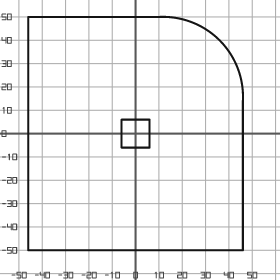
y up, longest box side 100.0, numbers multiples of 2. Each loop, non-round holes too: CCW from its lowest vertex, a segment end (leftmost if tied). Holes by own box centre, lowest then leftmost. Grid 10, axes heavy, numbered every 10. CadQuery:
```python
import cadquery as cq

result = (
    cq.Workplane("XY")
    .moveTo(-46.0, -50.0)
    .lineTo(46.0, -50.0)
    .lineTo(46.0, 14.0)
    .threePointArc((36.0, 40.0), (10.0, 50.0))
    .lineTo(-46.0, 50.0)
    .close()
    .moveTo(-6.0, -6.0)
    .lineTo(6.0, -6.0)
    .lineTo(6.0, 6.0)
    .lineTo(-6.0, 6.0)
    .close()
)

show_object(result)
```